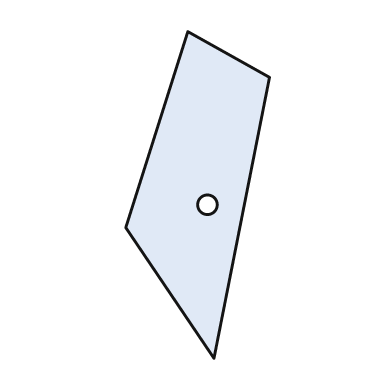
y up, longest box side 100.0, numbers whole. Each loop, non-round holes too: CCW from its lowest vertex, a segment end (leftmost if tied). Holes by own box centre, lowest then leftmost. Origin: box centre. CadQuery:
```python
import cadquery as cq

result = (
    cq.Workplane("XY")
    .moveTo(5.0, -50.0)
    .lineTo(22.0, 36.0)
    .lineTo(-3.0, 50.0)
    .lineTo(-22.0, -10.0)
    .close()
    .moveTo(3.0, -3.0)
    .circle(3.0)
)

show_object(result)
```